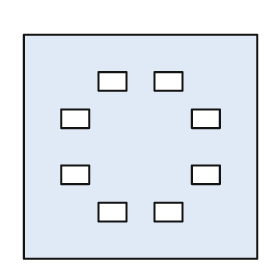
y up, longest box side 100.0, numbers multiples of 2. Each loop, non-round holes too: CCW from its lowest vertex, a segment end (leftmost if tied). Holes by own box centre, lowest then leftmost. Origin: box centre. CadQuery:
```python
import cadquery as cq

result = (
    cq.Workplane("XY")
    .moveTo(-50.0, -48.0)
    .lineTo(50.0, -48.0)
    .lineTo(50.0, 48.0)
    .lineTo(-50.0, 48.0)
    .close()
    .moveTo(-18.0, -32.0)
    .lineTo(-6.0, -32.0)
    .lineTo(-6.0, -24.0)
    .lineTo(-18.0, -24.0)
    .close()
    .moveTo(6.0, -32.0)
    .lineTo(18.0, -32.0)
    .lineTo(18.0, -24.0)
    .lineTo(6.0, -24.0)
    .close()
    .moveTo(-34.0, -16.0)
    .lineTo(-22.0, -16.0)
    .lineTo(-22.0, -8.0)
    .lineTo(-34.0, -8.0)
    .close()
    .moveTo(22.0, -16.0)
    .lineTo(34.0, -16.0)
    .lineTo(34.0, -8.0)
    .lineTo(22.0, -8.0)
    .close()
    .moveTo(-34.0, 8.0)
    .lineTo(-22.0, 8.0)
    .lineTo(-22.0, 16.0)
    .lineTo(-34.0, 16.0)
    .close()
    .moveTo(22.0, 8.0)
    .lineTo(34.0, 8.0)
    .lineTo(34.0, 16.0)
    .lineTo(22.0, 16.0)
    .close()
    .moveTo(-18.0, 24.0)
    .lineTo(-6.0, 24.0)
    .lineTo(-6.0, 32.0)
    .lineTo(-18.0, 32.0)
    .close()
    .moveTo(6.0, 24.0)
    .lineTo(18.0, 24.0)
    .lineTo(18.0, 32.0)
    .lineTo(6.0, 32.0)
    .close()
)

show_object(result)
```